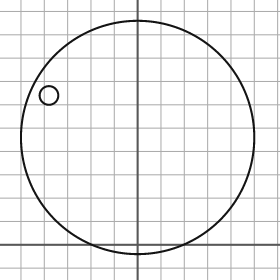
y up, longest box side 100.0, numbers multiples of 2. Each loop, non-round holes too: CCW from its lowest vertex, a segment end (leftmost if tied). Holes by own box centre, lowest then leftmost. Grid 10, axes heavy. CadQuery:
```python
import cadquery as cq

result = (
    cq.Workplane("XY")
    .moveTo(0.0, 46.0)
    .circle(50.0)
    .moveTo(-38.0, 64.0)
    .circle(4.0)
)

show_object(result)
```